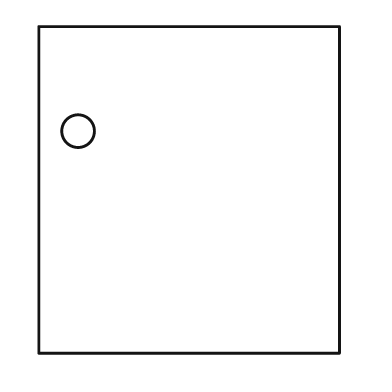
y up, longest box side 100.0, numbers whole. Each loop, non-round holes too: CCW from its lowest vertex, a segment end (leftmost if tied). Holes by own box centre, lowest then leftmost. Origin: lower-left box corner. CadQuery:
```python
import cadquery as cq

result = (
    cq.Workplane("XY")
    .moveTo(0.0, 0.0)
    .lineTo(92.0, 0.0)
    .lineTo(92.0, 100.0)
    .lineTo(0.0, 100.0)
    .close()
    .moveTo(12.0, 68.0)
    .circle(5.0)
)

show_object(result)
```